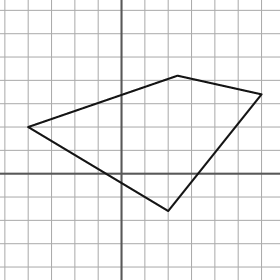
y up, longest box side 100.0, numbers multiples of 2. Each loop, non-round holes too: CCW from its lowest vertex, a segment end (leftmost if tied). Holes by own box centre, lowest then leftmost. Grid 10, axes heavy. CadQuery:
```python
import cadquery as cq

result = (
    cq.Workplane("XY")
    .moveTo(20.0, -16.0)
    .lineTo(60.0, 34.0)
    .lineTo(24.0, 42.0)
    .lineTo(-40.0, 20.0)
    .close()
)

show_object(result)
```